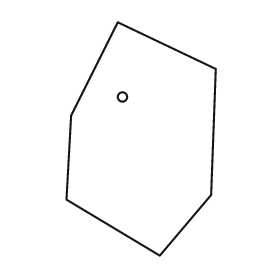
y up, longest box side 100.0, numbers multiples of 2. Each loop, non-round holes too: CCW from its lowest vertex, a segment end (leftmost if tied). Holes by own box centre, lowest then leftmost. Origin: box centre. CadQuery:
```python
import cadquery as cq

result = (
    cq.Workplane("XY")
    .moveTo(8.0, -50.0)
    .lineTo(30.0, -24.0)
    .lineTo(32.0, 30.0)
    .lineTo(-10.0, 50.0)
    .lineTo(-30.0, 10.0)
    .lineTo(-32.0, -26.0)
    .close()
    .moveTo(-8.0, 18.0)
    .circle(2.0)
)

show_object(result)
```